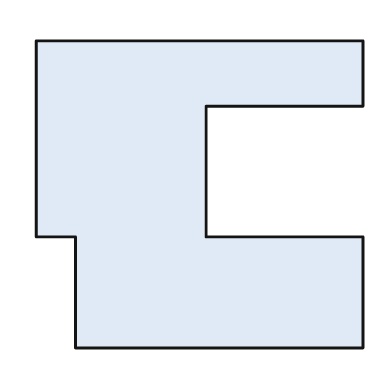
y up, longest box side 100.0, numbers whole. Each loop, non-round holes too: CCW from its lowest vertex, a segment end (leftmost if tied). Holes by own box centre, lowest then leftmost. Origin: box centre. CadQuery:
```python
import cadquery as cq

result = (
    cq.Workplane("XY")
    .moveTo(-38.0, -47.0)
    .lineTo(50.0, -47.0)
    .lineTo(50.0, -13.0)
    .lineTo(2.0, -13.0)
    .lineTo(2.0, 27.0)
    .lineTo(50.0, 27.0)
    .lineTo(50.0, 47.0)
    .lineTo(-50.0, 47.0)
    .lineTo(-50.0, -13.0)
    .lineTo(-38.0, -13.0)
    .close()
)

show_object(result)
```